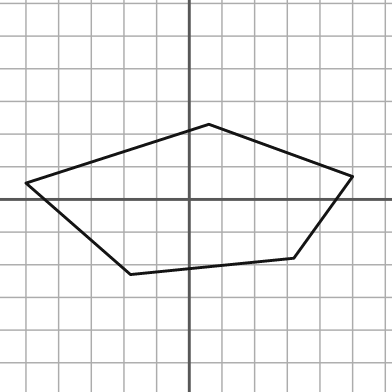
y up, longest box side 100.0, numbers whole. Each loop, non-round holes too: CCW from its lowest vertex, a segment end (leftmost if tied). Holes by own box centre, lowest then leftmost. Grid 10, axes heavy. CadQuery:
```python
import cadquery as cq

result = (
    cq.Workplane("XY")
    .moveTo(-18.0, -23.0)
    .lineTo(32.0, -18.0)
    .lineTo(50.0, 7.0)
    .lineTo(6.0, 23.0)
    .lineTo(-50.0, 5.0)
    .close()
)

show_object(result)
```